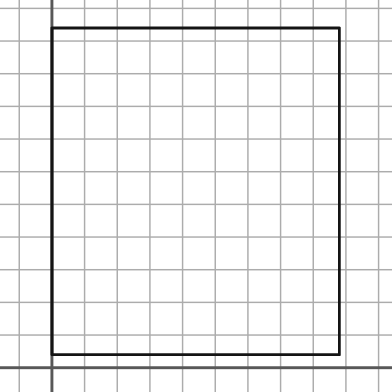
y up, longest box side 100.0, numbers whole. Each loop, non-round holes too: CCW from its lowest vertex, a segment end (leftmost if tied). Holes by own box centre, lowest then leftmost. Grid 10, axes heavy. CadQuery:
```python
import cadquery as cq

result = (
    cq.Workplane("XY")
    .moveTo(0.0, 4.0)
    .lineTo(88.0, 4.0)
    .lineTo(88.0, 104.0)
    .lineTo(0.0, 104.0)
    .close()
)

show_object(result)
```